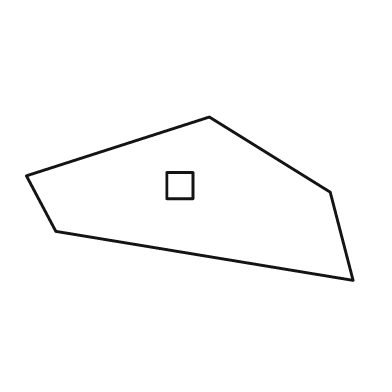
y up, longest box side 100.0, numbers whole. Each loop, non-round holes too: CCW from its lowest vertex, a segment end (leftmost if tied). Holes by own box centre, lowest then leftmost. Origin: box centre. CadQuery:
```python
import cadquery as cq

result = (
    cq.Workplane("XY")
    .moveTo(50.0, -25.0)
    .lineTo(43.0, 2.0)
    .lineTo(6.0, 25.0)
    .lineTo(-50.0, 7.0)
    .lineTo(-41.0, -10.0)
    .close()
    .moveTo(-7.0, 0.0)
    .lineTo(1.0, 0.0)
    .lineTo(1.0, 8.0)
    .lineTo(-7.0, 8.0)
    .close()
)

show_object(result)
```